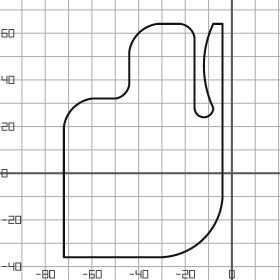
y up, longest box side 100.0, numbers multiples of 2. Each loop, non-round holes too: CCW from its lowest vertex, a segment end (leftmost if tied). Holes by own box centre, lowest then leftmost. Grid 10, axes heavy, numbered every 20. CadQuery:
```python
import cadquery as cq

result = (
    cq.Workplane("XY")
    .moveTo(-72.0, -36.0)
    .lineTo(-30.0, -36.0)
    .threePointArc((-12.0, -28.0), (-4.0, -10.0))
    .lineTo(-4.0, 64.0)
    .lineTo(-8.0, 64.0)
    .threePointArc((-12.0, 46.0), (-8.0, 28.0))
    .threePointArc((-12.0, 24.0), (-16.0, 28.0))
    .lineTo(-16.0, 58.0)
    .threePointArc((-18.0, 62.0), (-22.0, 64.0))
    .lineTo(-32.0, 64.0)
    .threePointArc((-40.0, 60.0), (-44.0, 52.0))
    .lineTo(-44.0, 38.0)
    .threePointArc((-46.0, 34.0), (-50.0, 32.0))
    .lineTo(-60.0, 32.0)
    .threePointArc((-68.0, 28.0), (-72.0, 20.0))
    .close()
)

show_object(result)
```